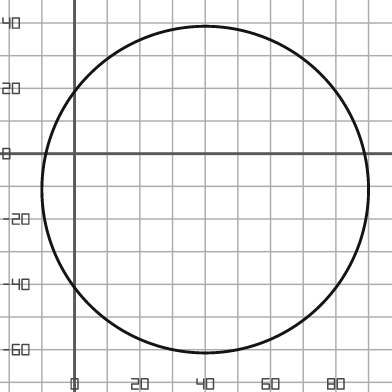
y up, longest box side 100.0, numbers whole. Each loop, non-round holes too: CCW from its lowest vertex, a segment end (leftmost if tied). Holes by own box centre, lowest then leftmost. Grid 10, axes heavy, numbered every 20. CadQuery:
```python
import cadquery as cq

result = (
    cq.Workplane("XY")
    .moveTo(40.0, -11.0)
    .circle(50.0)
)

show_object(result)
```